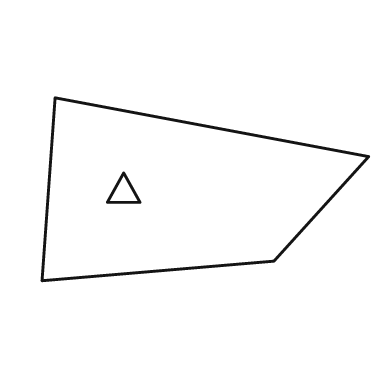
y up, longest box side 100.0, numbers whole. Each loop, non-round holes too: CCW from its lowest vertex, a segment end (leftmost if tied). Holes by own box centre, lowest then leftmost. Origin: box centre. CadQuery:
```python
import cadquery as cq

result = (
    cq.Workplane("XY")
    .moveTo(-50.0, -28.0)
    .lineTo(21.0, -22.0)
    .lineTo(50.0, 10.0)
    .lineTo(-46.0, 28.0)
    .close()
    .moveTo(-30.0, -4.0)
    .lineTo(-20.0, -4.0)
    .lineTo(-25.0, 5.0)
    .close()
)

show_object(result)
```